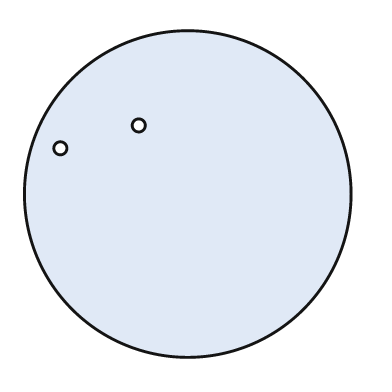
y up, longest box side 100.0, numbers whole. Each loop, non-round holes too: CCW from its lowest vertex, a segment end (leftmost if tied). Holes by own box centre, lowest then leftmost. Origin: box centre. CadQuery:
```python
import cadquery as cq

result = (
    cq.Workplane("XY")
    .moveTo(0.0, 0.0)
    .circle(50.0)
    .moveTo(-39.0, 14.0)
    .circle(2.0)
    .moveTo(-15.0, 21.0)
    .circle(2.0)
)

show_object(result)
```